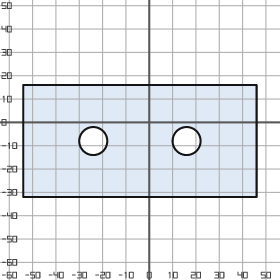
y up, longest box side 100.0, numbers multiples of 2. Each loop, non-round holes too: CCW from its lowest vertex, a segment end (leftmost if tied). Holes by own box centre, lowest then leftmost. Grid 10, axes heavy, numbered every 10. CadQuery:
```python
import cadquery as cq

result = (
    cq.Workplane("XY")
    .moveTo(-54.0, -32.0)
    .lineTo(46.0, -32.0)
    .lineTo(46.0, 16.0)
    .lineTo(-54.0, 16.0)
    .close()
    .moveTo(-24.0, -8.0)
    .circle(6.0)
    .moveTo(16.0, -8.0)
    .circle(6.0)
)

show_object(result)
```